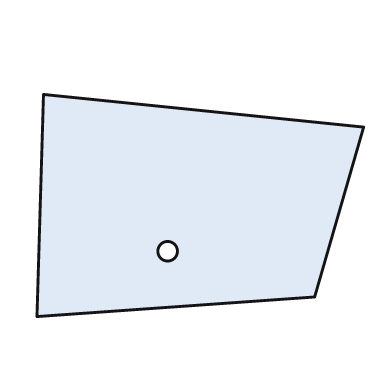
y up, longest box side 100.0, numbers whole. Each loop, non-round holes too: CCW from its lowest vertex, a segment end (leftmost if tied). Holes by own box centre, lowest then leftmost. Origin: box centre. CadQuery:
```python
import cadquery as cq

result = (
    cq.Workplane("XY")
    .moveTo(-50.0, -34.0)
    .lineTo(35.0, -28.0)
    .lineTo(50.0, 24.0)
    .lineTo(-48.0, 34.0)
    .close()
    .moveTo(-10.0, -14.0)
    .circle(3.0)
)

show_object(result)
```